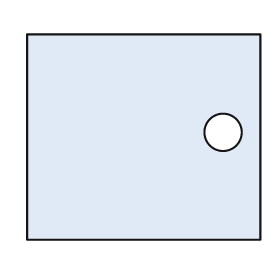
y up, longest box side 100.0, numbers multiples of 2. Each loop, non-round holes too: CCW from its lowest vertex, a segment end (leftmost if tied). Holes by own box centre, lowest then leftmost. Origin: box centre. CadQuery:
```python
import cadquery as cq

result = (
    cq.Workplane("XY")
    .moveTo(-50.0, -44.0)
    .lineTo(50.0, -44.0)
    .lineTo(50.0, 44.0)
    .lineTo(-50.0, 44.0)
    .close()
    .moveTo(34.0, 2.0)
    .circle(8.0)
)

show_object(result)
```